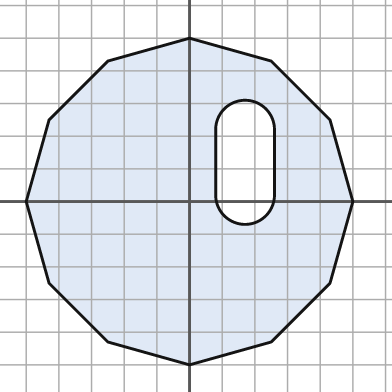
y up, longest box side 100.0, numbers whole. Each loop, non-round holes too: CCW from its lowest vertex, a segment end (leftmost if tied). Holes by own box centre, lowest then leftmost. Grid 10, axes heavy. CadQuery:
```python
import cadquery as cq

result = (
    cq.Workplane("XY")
    .moveTo(0.0, -50.0)
    .lineTo(25.0, -43.0)
    .lineTo(43.0, -25.0)
    .lineTo(50.0, 0.0)
    .lineTo(43.0, 25.0)
    .lineTo(25.0, 43.0)
    .lineTo(0.0, 50.0)
    .lineTo(-25.0, 43.0)
    .lineTo(-43.0, 25.0)
    .lineTo(-50.0, 0.0)
    .lineTo(-43.0, -25.0)
    .lineTo(-25.0, -43.0)
    .close()
    .moveTo(8.0, 2.0)
    .threePointArc((17.0, -7.0), (26.0, 2.0))
    .lineTo(26.0, 22.0)
    .threePointArc((17.0, 31.0), (8.0, 22.0))
    .close()
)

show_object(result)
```